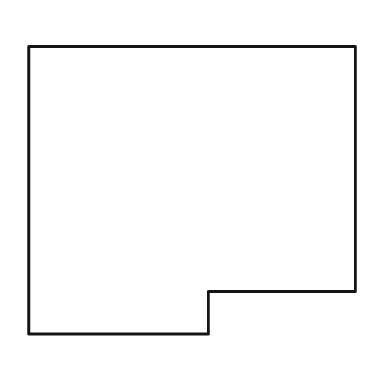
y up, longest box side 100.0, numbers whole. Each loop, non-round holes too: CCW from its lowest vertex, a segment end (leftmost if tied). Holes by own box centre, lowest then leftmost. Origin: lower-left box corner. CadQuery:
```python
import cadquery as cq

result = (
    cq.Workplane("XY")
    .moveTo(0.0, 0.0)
    .lineTo(55.0, 0.0)
    .lineTo(55.0, 13.0)
    .lineTo(100.0, 13.0)
    .lineTo(100.0, 88.0)
    .lineTo(0.0, 88.0)
    .close()
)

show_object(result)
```